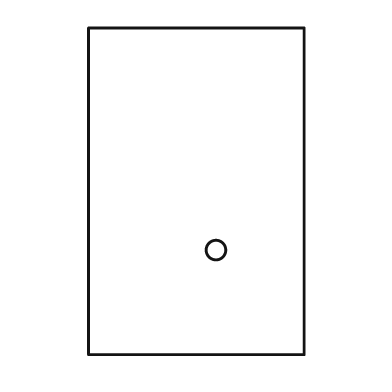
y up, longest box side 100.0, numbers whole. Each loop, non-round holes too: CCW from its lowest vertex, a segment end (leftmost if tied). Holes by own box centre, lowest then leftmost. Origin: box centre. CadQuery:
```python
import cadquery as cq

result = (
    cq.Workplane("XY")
    .moveTo(-33.0, -50.0)
    .lineTo(33.0, -50.0)
    .lineTo(33.0, 50.0)
    .lineTo(-33.0, 50.0)
    .close()
    .moveTo(6.0, -18.0)
    .circle(3.0)
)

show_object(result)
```